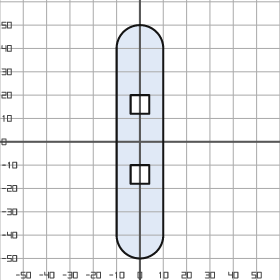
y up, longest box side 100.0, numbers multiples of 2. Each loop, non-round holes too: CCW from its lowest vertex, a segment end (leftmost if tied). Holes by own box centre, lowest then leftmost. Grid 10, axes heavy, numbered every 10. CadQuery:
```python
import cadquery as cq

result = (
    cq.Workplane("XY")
    .moveTo(-10.0, -40.0)
    .threePointArc((0.0, -50.0), (10.0, -40.0))
    .lineTo(10.0, 40.0)
    .threePointArc((0.0, 50.0), (-10.0, 40.0))
    .close()
    .moveTo(-4.0, -18.0)
    .lineTo(4.0, -18.0)
    .lineTo(4.0, -10.0)
    .lineTo(-4.0, -10.0)
    .close()
    .moveTo(-4.0, 12.0)
    .lineTo(4.0, 12.0)
    .lineTo(4.0, 20.0)
    .lineTo(-4.0, 20.0)
    .close()
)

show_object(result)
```